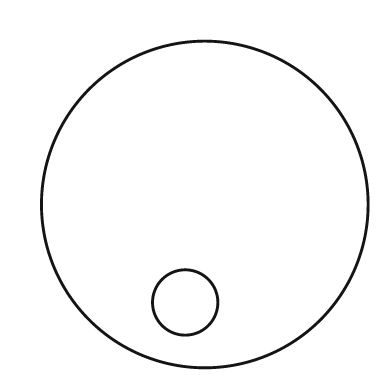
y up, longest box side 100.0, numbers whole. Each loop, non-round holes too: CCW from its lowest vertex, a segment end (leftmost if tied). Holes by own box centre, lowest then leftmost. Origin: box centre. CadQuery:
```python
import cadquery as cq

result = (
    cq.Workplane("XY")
    .moveTo(0.0, 0.0)
    .circle(50.0)
    .moveTo(-6.0, -30.0)
    .circle(10.0)
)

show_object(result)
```